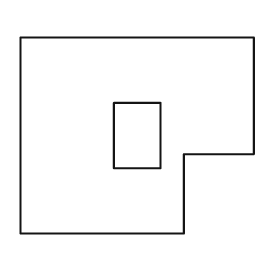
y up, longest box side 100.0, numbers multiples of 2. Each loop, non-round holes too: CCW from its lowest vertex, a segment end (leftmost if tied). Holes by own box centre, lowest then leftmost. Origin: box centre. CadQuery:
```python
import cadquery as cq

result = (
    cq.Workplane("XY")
    .moveTo(-50.0, -42.0)
    .lineTo(20.0, -42.0)
    .lineTo(20.0, -8.0)
    .lineTo(50.0, -8.0)
    .lineTo(50.0, 42.0)
    .lineTo(-50.0, 42.0)
    .close()
    .moveTo(-10.0, -14.0)
    .lineTo(10.0, -14.0)
    .lineTo(10.0, 14.0)
    .lineTo(-10.0, 14.0)
    .close()
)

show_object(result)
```